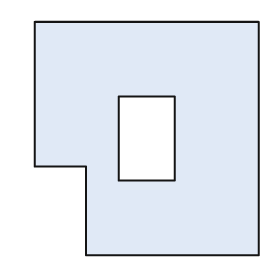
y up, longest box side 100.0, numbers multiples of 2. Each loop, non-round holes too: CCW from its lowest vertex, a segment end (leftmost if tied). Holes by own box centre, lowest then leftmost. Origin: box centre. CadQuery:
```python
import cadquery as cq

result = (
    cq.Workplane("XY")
    .moveTo(-26.0, -50.0)
    .lineTo(48.0, -50.0)
    .lineTo(48.0, 50.0)
    .lineTo(-48.0, 50.0)
    .lineTo(-48.0, -12.0)
    .lineTo(-26.0, -12.0)
    .close()
    .moveTo(-12.0, -18.0)
    .lineTo(12.0, -18.0)
    .lineTo(12.0, 18.0)
    .lineTo(-12.0, 18.0)
    .close()
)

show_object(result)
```